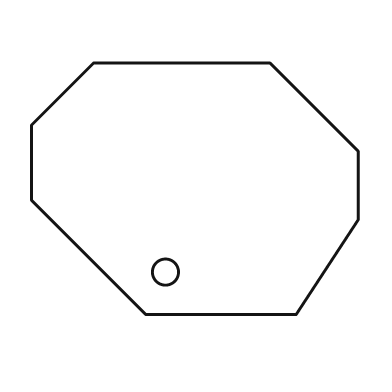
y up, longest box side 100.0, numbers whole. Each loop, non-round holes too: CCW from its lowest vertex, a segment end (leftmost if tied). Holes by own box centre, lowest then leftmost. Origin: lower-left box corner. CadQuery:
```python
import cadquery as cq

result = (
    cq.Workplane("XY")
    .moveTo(35.0, 0.0)
    .lineTo(81.0, 0.0)
    .lineTo(100.0, 29.0)
    .lineTo(100.0, 50.0)
    .lineTo(73.0, 77.0)
    .lineTo(19.0, 77.0)
    .lineTo(0.0, 58.0)
    .lineTo(0.0, 35.0)
    .close()
    .moveTo(41.0, 13.0)
    .circle(4.0)
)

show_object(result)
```